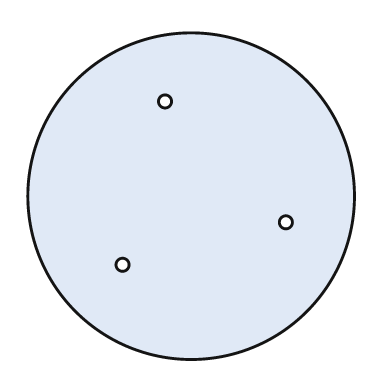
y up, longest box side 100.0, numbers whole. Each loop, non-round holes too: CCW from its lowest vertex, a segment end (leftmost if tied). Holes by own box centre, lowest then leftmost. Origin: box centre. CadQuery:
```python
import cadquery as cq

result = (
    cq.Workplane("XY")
    .moveTo(0.0, 0.0)
    .circle(50.0)
    .moveTo(-21.0, -21.0)
    .circle(2.0)
    .moveTo(29.0, -8.0)
    .circle(2.0)
    .moveTo(-8.0, 29.0)
    .circle(2.0)
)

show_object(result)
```